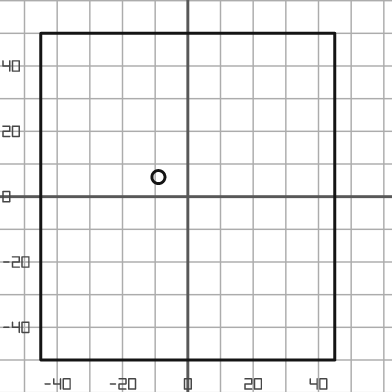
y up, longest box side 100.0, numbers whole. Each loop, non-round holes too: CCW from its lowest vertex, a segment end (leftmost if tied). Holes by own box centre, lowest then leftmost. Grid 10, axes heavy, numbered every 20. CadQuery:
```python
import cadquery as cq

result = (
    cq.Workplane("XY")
    .moveTo(-45.0, -50.0)
    .lineTo(45.0, -50.0)
    .lineTo(45.0, 50.0)
    .lineTo(-45.0, 50.0)
    .close()
    .moveTo(-9.0, 6.0)
    .circle(2.0)
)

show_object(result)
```